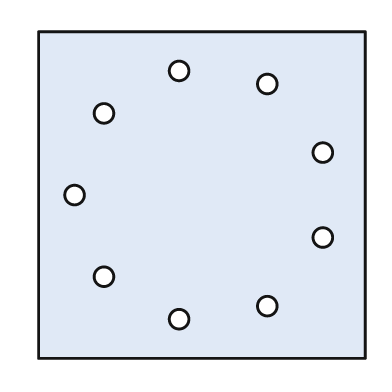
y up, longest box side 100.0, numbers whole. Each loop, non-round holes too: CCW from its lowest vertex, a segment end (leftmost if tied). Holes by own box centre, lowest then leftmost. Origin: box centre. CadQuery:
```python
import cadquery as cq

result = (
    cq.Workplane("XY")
    .moveTo(-50.0, -50.0)
    .lineTo(50.0, -50.0)
    .lineTo(50.0, 50.0)
    .lineTo(-50.0, 50.0)
    .close()
    .moveTo(-7.0, -38.0)
    .circle(3.0)
    .moveTo(20.0, -34.0)
    .circle(3.0)
    .moveTo(-30.0, -25.0)
    .circle(3.0)
    .moveTo(37.0, -13.0)
    .circle(3.0)
    .moveTo(-39.0, 0.0)
    .circle(3.0)
    .moveTo(37.0, 13.0)
    .circle(3.0)
    .moveTo(-30.0, 25.0)
    .circle(3.0)
    .moveTo(20.0, 34.0)
    .circle(3.0)
    .moveTo(-7.0, 38.0)
    .circle(3.0)
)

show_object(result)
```